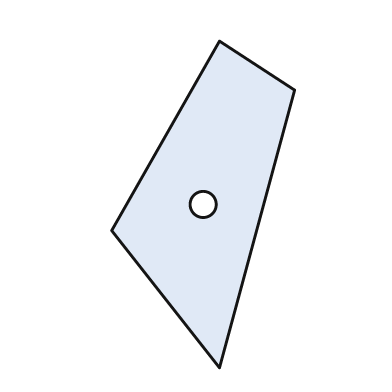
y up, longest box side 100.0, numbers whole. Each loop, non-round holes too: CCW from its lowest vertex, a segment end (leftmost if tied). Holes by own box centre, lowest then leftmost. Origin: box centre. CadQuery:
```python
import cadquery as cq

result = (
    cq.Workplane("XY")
    .moveTo(5.0, -50.0)
    .lineTo(28.0, 35.0)
    .lineTo(5.0, 50.0)
    .lineTo(-28.0, -8.0)
    .close()
    .moveTo(0.0, 0.0)
    .circle(4.0)
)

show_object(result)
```